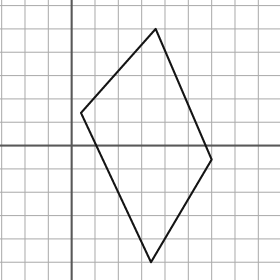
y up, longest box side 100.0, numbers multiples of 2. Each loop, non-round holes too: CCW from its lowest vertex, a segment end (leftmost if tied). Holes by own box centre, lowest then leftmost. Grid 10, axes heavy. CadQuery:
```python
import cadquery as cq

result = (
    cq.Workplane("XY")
    .moveTo(34.0, -50.0)
    .lineTo(60.0, -6.0)
    .lineTo(36.0, 50.0)
    .lineTo(4.0, 14.0)
    .close()
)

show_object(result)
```